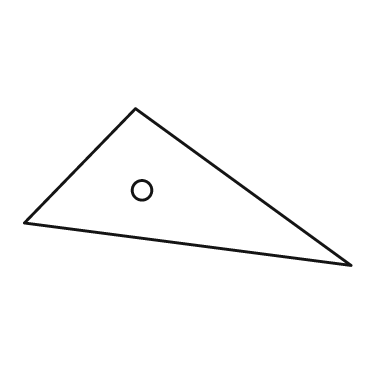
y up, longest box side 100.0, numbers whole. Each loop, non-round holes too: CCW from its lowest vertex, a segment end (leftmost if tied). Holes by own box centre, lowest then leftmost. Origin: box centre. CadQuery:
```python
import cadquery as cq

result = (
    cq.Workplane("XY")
    .moveTo(50.0, -24.0)
    .lineTo(-16.0, 24.0)
    .lineTo(-50.0, -11.0)
    .close()
    .moveTo(-14.0, -1.0)
    .circle(3.0)
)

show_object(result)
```